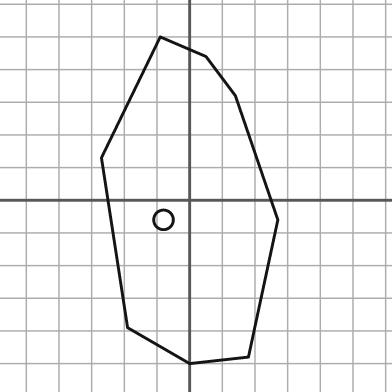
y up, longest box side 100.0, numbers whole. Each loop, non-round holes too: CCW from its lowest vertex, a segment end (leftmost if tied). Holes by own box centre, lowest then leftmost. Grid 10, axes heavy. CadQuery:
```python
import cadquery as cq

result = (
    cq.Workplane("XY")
    .moveTo(0.0, -50.0)
    .lineTo(18.0, -48.0)
    .lineTo(27.0, -6.0)
    .lineTo(14.0, 32.0)
    .lineTo(5.0, 44.0)
    .lineTo(-9.0, 50.0)
    .lineTo(-27.0, 13.0)
    .lineTo(-19.0, -39.0)
    .close()
    .moveTo(-8.0, -6.0)
    .circle(3.0)
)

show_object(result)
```